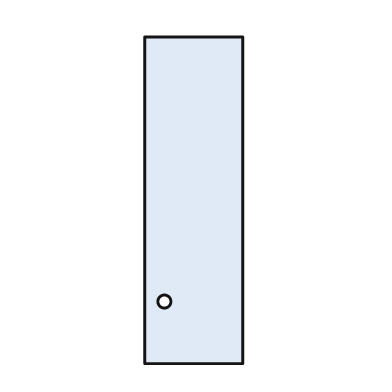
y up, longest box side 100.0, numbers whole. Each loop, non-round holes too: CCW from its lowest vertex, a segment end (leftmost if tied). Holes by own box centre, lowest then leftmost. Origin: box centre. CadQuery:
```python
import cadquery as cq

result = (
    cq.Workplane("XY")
    .moveTo(-15.0, -50.0)
    .lineTo(15.0, -50.0)
    .lineTo(15.0, 50.0)
    .lineTo(-15.0, 50.0)
    .close()
    .moveTo(-9.0, -31.0)
    .circle(2.0)
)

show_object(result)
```